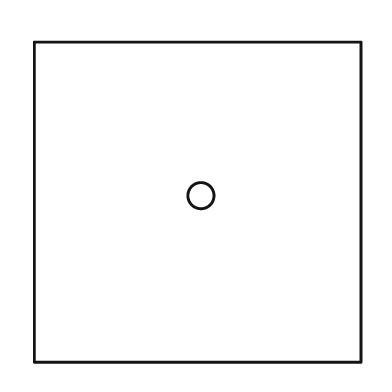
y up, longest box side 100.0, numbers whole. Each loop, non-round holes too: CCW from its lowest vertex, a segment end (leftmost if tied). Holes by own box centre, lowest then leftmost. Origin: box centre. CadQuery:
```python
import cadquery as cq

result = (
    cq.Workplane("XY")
    .moveTo(-50.0, -49.0)
    .lineTo(50.0, -49.0)
    .lineTo(50.0, 49.0)
    .lineTo(-50.0, 49.0)
    .close()
    .moveTo(1.0, 2.0)
    .circle(4.0)
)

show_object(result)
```